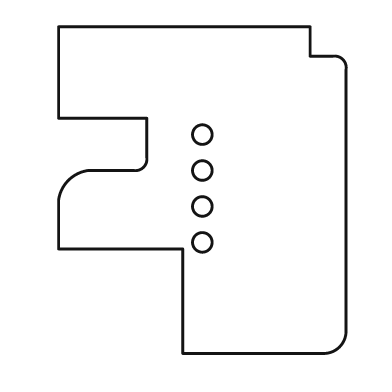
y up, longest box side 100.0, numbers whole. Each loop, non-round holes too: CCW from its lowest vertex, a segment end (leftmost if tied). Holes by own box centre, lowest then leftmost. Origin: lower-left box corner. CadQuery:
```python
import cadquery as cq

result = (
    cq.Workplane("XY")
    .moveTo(38.0, 0.0)
    .lineTo(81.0, 0.0)
    .threePointArc((86.0, 2.0), (88.0, 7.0))
    .lineTo(88.0, 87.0)
    .threePointArc((87.0, 90.0), (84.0, 91.0))
    .lineTo(77.0, 91.0)
    .lineTo(77.0, 100.0)
    .lineTo(0.0, 100.0)
    .lineTo(0.0, 72.0)
    .lineTo(27.0, 72.0)
    .lineTo(27.0, 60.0)
    .threePointArc((26.0, 57.0), (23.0, 56.0))
    .lineTo(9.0, 56.0)
    .threePointArc((3.0, 53.0), (0.0, 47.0))
    .lineTo(0.0, 32.0)
    .lineTo(38.0, 32.0)
    .close()
    .moveTo(44.0, 34.0)
    .circle(3.0)
    .moveTo(44.0, 45.0)
    .circle(3.0)
    .moveTo(44.0, 56.0)
    .circle(3.0)
    .moveTo(44.0, 67.0)
    .circle(3.0)
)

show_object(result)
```